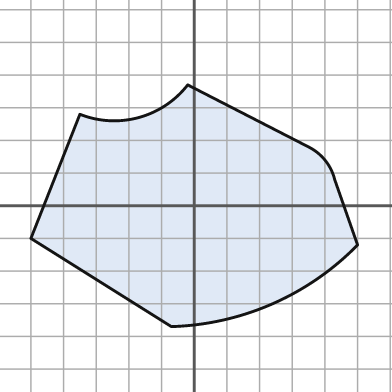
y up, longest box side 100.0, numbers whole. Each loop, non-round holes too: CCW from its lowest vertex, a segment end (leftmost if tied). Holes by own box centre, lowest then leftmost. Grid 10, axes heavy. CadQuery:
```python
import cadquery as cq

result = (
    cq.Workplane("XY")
    .moveTo(-7.0, -37.0)
    .threePointArc((24.0, -30.0), (50.0, -12.0))
    .lineTo(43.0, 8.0)
    .threePointArc((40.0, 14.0), (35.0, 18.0))
    .lineTo(-2.0, 37.0)
    .threePointArc((-17.0, 27.0), (-35.0, 28.0))
    .lineTo(-50.0, -10.0)
    .close()
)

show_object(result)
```